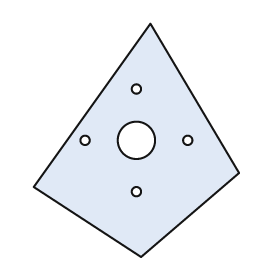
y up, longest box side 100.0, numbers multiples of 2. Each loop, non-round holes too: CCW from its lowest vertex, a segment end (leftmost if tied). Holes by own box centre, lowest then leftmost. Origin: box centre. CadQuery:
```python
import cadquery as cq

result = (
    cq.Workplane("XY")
    .moveTo(2.0, -50.0)
    .lineTo(44.0, -14.0)
    .lineTo(6.0, 50.0)
    .lineTo(-44.0, -20.0)
    .close()
    .moveTo(0.0, -22.0)
    .circle(2.0)
    .moveTo(-22.0, 0.0)
    .circle(2.0)
    .moveTo(0.0, 0.0)
    .circle(8.0)
    .moveTo(22.0, 0.0)
    .circle(2.0)
    .moveTo(0.0, 22.0)
    .circle(2.0)
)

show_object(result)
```